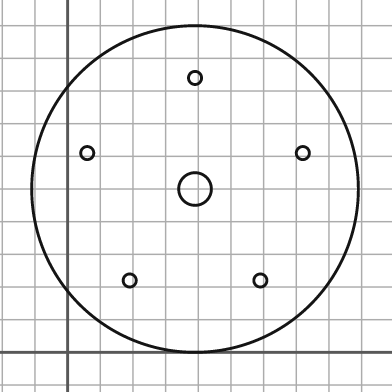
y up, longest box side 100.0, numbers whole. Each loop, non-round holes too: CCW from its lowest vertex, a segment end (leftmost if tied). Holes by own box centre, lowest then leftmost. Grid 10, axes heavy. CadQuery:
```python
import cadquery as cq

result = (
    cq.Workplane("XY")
    .moveTo(39.0, 50.0)
    .circle(50.0)
    .moveTo(19.0, 22.0)
    .circle(2.0)
    .moveTo(59.0, 22.0)
    .circle(2.0)
    .moveTo(39.0, 50.0)
    .circle(5.0)
    .moveTo(6.0, 61.0)
    .circle(2.0)
    .moveTo(72.0, 61.0)
    .circle(2.0)
    .moveTo(39.0, 84.0)
    .circle(2.0)
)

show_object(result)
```